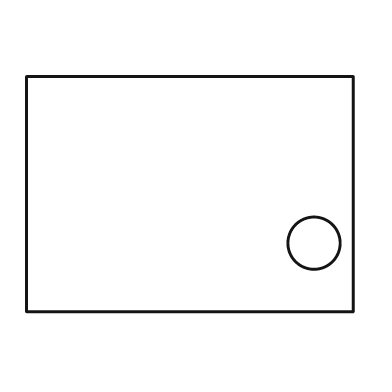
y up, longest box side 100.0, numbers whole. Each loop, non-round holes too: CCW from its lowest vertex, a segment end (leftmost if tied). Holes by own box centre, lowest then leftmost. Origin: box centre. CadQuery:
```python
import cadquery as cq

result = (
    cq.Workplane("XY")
    .moveTo(-50.0, -36.0)
    .lineTo(50.0, -36.0)
    .lineTo(50.0, 36.0)
    .lineTo(-50.0, 36.0)
    .close()
    .moveTo(38.0, -15.0)
    .circle(8.0)
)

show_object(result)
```